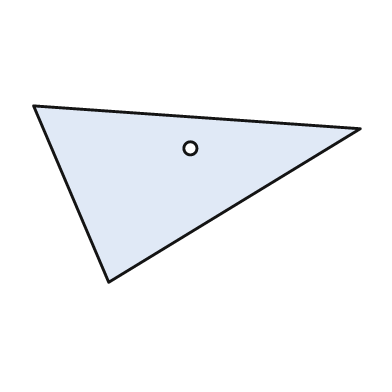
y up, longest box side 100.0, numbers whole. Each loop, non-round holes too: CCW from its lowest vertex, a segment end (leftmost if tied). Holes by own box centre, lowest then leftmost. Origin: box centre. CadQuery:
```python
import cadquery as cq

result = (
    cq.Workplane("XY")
    .moveTo(-27.0, -27.0)
    .lineTo(50.0, 20.0)
    .lineTo(-50.0, 27.0)
    .close()
    .moveTo(-2.0, 14.0)
    .circle(2.0)
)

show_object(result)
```